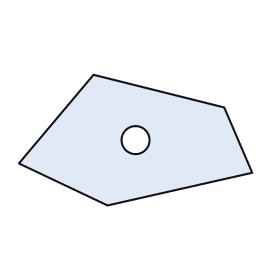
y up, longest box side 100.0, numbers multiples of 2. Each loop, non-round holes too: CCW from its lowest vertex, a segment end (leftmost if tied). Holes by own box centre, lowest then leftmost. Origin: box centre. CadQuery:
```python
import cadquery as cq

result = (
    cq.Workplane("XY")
    .moveTo(-12.0, -28.0)
    .lineTo(50.0, -14.0)
    .lineTo(38.0, 14.0)
    .lineTo(-18.0, 28.0)
    .lineTo(-50.0, -10.0)
    .close()
    .moveTo(0.0, 0.0)
    .circle(6.0)
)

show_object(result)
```